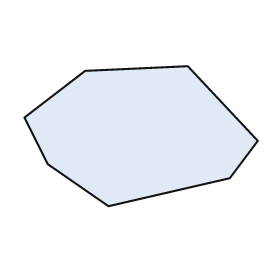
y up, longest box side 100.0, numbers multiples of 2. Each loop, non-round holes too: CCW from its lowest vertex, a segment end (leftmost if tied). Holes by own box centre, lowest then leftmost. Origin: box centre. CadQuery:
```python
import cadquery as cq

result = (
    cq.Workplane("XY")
    .moveTo(-14.0, -30.0)
    .lineTo(38.0, -18.0)
    .lineTo(50.0, -2.0)
    .lineTo(20.0, 30.0)
    .lineTo(-24.0, 28.0)
    .lineTo(-50.0, 8.0)
    .lineTo(-40.0, -12.0)
    .close()
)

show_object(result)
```